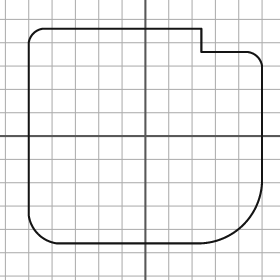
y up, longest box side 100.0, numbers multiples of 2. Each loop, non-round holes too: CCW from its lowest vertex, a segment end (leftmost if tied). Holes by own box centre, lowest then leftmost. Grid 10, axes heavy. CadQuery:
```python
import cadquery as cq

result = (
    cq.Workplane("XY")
    .moveTo(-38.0, -46.0)
    .lineTo(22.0, -46.0)
    .threePointArc((42.0, -38.0), (50.0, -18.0))
    .lineTo(50.0, 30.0)
    .threePointArc((48.0, 34.0), (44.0, 36.0))
    .lineTo(24.0, 36.0)
    .lineTo(24.0, 46.0)
    .lineTo(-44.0, 46.0)
    .threePointArc((-48.0, 44.0), (-50.0, 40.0))
    .lineTo(-50.0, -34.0)
    .threePointArc((-46.0, -42.0), (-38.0, -46.0))
    .close()
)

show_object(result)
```